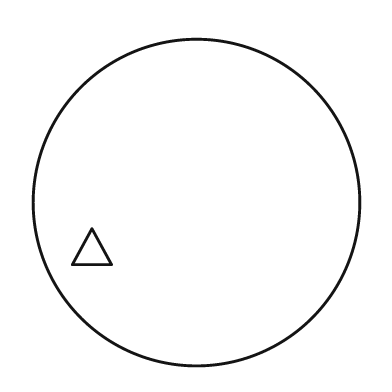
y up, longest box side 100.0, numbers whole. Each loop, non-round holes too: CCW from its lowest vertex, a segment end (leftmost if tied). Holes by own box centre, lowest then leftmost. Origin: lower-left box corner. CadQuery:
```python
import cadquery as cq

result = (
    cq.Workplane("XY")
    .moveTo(50.0, 50.0)
    .circle(50.0)
    .moveTo(12.0, 31.0)
    .lineTo(24.0, 31.0)
    .lineTo(18.0, 42.0)
    .close()
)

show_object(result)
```